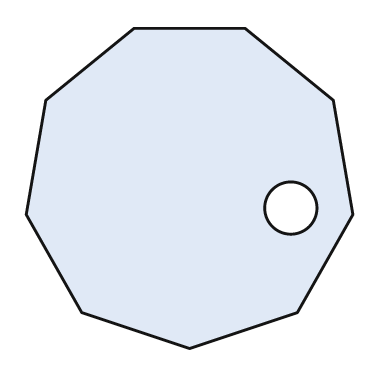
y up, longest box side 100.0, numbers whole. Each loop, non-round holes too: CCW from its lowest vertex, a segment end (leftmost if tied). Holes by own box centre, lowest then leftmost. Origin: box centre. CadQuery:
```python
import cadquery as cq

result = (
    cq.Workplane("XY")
    .moveTo(0.0, -49.0)
    .lineTo(33.0, -38.0)
    .lineTo(50.0, -8.0)
    .lineTo(44.0, 27.0)
    .lineTo(17.0, 49.0)
    .lineTo(-17.0, 49.0)
    .lineTo(-44.0, 27.0)
    .lineTo(-50.0, -8.0)
    .lineTo(-33.0, -38.0)
    .close()
    .moveTo(31.0, -6.0)
    .circle(8.0)
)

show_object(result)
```